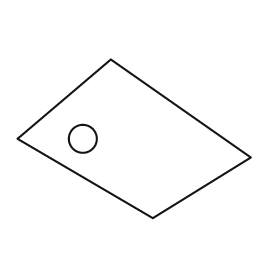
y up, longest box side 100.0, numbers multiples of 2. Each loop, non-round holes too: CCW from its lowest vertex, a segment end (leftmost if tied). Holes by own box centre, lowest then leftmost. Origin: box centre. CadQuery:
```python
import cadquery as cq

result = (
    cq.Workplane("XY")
    .moveTo(8.0, -34.0)
    .lineTo(50.0, -8.0)
    .lineTo(-10.0, 34.0)
    .lineTo(-50.0, 0.0)
    .close()
    .moveTo(-22.0, 0.0)
    .circle(6.0)
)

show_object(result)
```